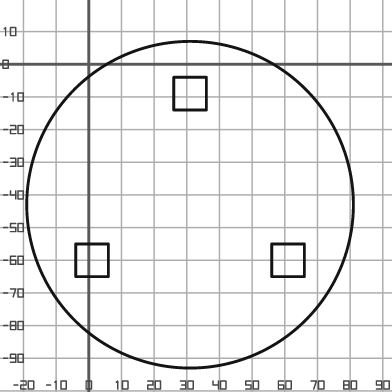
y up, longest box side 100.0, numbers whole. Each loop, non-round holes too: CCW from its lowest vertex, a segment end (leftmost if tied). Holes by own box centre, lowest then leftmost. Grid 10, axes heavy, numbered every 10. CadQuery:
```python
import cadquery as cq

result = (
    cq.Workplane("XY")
    .moveTo(31.0, -43.0)
    .circle(50.0)
    .moveTo(-4.0, -65.0)
    .lineTo(6.0, -65.0)
    .lineTo(6.0, -55.0)
    .lineTo(-4.0, -55.0)
    .close()
    .moveTo(56.0, -65.0)
    .lineTo(66.0, -65.0)
    .lineTo(66.0, -55.0)
    .lineTo(56.0, -55.0)
    .close()
    .moveTo(26.0, -14.0)
    .lineTo(36.0, -14.0)
    .lineTo(36.0, -4.0)
    .lineTo(26.0, -4.0)
    .close()
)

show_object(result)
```